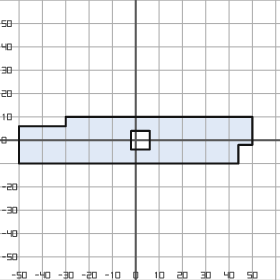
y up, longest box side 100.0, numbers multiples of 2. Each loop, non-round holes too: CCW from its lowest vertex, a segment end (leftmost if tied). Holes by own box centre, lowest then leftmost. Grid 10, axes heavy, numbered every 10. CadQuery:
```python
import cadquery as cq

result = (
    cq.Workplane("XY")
    .moveTo(-50.0, -10.0)
    .lineTo(44.0, -10.0)
    .lineTo(44.0, -2.0)
    .lineTo(50.0, -2.0)
    .lineTo(50.0, 10.0)
    .lineTo(-30.0, 10.0)
    .lineTo(-30.0, 6.0)
    .lineTo(-50.0, 6.0)
    .close()
    .moveTo(-2.0, -4.0)
    .lineTo(6.0, -4.0)
    .lineTo(6.0, 4.0)
    .lineTo(-2.0, 4.0)
    .close()
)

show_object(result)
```